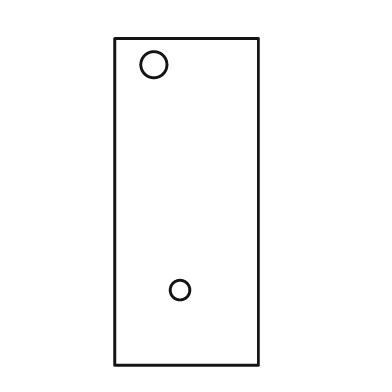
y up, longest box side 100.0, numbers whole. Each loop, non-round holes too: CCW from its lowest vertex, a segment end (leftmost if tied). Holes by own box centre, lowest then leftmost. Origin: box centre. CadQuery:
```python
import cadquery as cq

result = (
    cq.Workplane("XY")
    .moveTo(-22.0, -50.0)
    .lineTo(22.0, -50.0)
    .lineTo(22.0, 50.0)
    .lineTo(-22.0, 50.0)
    .close()
    .moveTo(-2.0, -27.0)
    .circle(3.0)
    .moveTo(-10.0, 42.0)
    .circle(4.0)
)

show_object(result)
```